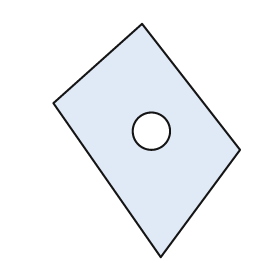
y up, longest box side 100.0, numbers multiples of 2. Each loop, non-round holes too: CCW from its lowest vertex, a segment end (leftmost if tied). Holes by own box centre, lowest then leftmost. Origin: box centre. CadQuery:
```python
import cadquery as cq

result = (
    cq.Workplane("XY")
    .moveTo(6.0, -50.0)
    .lineTo(40.0, -4.0)
    .lineTo(-2.0, 50.0)
    .lineTo(-40.0, 16.0)
    .close()
    .moveTo(2.0, 4.0)
    .circle(8.0)
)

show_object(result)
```